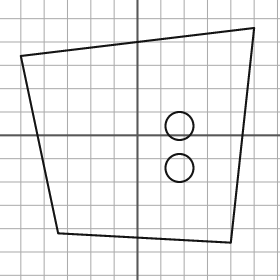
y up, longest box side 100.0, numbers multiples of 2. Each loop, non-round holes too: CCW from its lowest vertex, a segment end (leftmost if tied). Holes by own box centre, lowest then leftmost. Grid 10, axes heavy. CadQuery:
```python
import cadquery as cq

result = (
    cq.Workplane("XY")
    .moveTo(40.0, -46.0)
    .lineTo(50.0, 46.0)
    .lineTo(-50.0, 34.0)
    .lineTo(-34.0, -42.0)
    .close()
    .moveTo(18.0, -14.0)
    .circle(6.0)
    .moveTo(18.0, 4.0)
    .circle(6.0)
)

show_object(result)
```